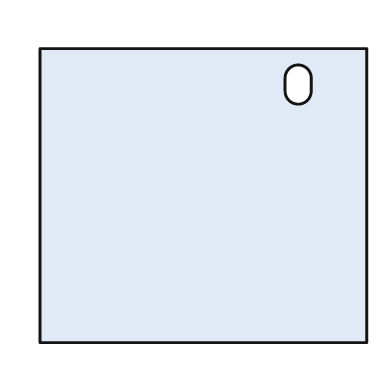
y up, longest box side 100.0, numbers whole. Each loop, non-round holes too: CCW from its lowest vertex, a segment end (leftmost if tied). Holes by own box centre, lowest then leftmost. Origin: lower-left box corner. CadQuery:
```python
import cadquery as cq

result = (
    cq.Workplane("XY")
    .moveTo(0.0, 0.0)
    .lineTo(100.0, 0.0)
    .lineTo(100.0, 90.0)
    .lineTo(0.0, 90.0)
    .close()
    .moveTo(75.0, 77.0)
    .threePointArc((79.0, 73.0), (83.0, 77.0))
    .lineTo(83.0, 81.0)
    .threePointArc((79.0, 85.0), (75.0, 81.0))
    .close()
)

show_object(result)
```